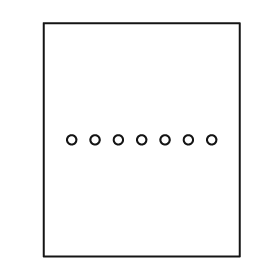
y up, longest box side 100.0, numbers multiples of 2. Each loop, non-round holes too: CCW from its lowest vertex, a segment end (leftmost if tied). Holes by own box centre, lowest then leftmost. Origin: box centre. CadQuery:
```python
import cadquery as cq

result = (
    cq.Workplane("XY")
    .moveTo(-42.0, -50.0)
    .lineTo(42.0, -50.0)
    .lineTo(42.0, 50.0)
    .lineTo(-42.0, 50.0)
    .close()
    .moveTo(-30.0, 0.0)
    .circle(2.0)
    .moveTo(-20.0, 0.0)
    .circle(2.0)
    .moveTo(-10.0, 0.0)
    .circle(2.0)
    .moveTo(0.0, 0.0)
    .circle(2.0)
    .moveTo(10.0, 0.0)
    .circle(2.0)
    .moveTo(20.0, 0.0)
    .circle(2.0)
    .moveTo(30.0, 0.0)
    .circle(2.0)
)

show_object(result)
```